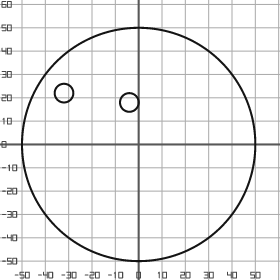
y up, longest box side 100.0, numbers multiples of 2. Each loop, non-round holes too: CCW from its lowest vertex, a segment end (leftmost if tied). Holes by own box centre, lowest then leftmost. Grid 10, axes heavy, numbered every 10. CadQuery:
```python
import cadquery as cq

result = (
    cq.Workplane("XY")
    .moveTo(0.0, 0.0)
    .circle(50.0)
    .moveTo(-4.0, 18.0)
    .circle(4.0)
    .moveTo(-32.0, 22.0)
    .circle(4.0)
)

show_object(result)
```